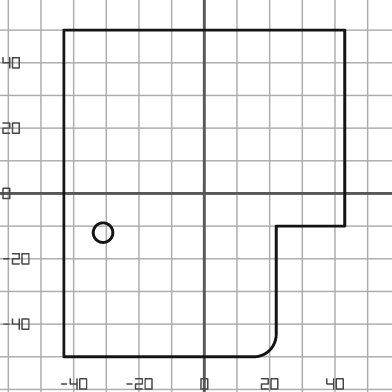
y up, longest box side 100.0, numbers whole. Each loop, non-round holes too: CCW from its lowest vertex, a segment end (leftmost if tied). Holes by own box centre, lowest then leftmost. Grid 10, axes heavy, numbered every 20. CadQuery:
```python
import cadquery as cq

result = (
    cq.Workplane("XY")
    .moveTo(-43.0, -50.0)
    .lineTo(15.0, -50.0)
    .threePointArc((20.0, -48.0), (22.0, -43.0))
    .lineTo(22.0, -10.0)
    .lineTo(43.0, -10.0)
    .lineTo(43.0, 50.0)
    .lineTo(-43.0, 50.0)
    .close()
    .moveTo(-31.0, -12.0)
    .circle(3.0)
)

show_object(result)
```